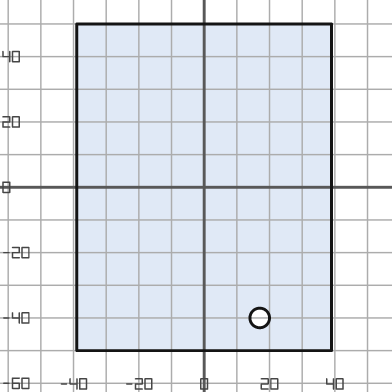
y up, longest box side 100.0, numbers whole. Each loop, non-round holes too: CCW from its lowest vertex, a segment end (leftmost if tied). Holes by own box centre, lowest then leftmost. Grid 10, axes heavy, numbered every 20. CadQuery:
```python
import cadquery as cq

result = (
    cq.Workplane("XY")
    .moveTo(-39.0, -50.0)
    .lineTo(39.0, -50.0)
    .lineTo(39.0, 50.0)
    .lineTo(-39.0, 50.0)
    .close()
    .moveTo(17.0, -40.0)
    .circle(3.0)
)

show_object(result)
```